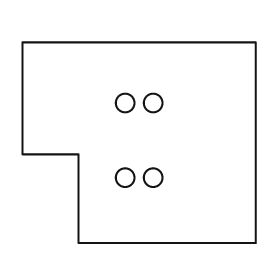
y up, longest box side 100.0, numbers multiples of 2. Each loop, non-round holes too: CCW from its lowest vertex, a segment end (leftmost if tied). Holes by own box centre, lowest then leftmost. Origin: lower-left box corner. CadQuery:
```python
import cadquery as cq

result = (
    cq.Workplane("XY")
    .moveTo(24.0, 0.0)
    .lineTo(100.0, 0.0)
    .lineTo(100.0, 86.0)
    .lineTo(0.0, 86.0)
    .lineTo(0.0, 38.0)
    .lineTo(24.0, 38.0)
    .close()
    .moveTo(44.0, 28.0)
    .circle(4.0)
    .moveTo(56.0, 28.0)
    .circle(4.0)
    .moveTo(44.0, 60.0)
    .circle(4.0)
    .moveTo(56.0, 60.0)
    .circle(4.0)
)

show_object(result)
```